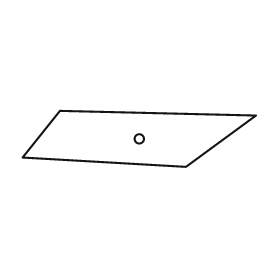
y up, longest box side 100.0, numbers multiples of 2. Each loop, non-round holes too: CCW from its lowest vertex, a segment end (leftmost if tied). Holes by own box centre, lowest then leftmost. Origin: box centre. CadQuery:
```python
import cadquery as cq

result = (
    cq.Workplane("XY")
    .moveTo(20.0, -12.0)
    .lineTo(50.0, 10.0)
    .lineTo(-34.0, 12.0)
    .lineTo(-50.0, -8.0)
    .close()
    .moveTo(0.0, 0.0)
    .circle(2.0)
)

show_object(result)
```